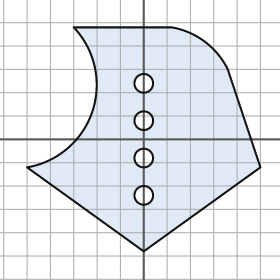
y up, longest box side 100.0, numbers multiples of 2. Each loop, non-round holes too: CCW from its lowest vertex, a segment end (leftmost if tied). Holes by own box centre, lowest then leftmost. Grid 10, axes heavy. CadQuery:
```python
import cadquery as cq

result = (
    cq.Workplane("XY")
    .moveTo(0.0, -48.0)
    .lineTo(50.0, -12.0)
    .lineTo(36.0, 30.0)
    .threePointArc((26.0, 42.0), (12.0, 48.0))
    .lineTo(-30.0, 48.0)
    .threePointArc((-22.0, 12.0), (-50.0, -12.0))
    .close()
    .moveTo(0.0, -24.0)
    .circle(4.0)
    .moveTo(0.0, -8.0)
    .circle(4.0)
    .moveTo(0.0, 8.0)
    .circle(4.0)
    .moveTo(0.0, 24.0)
    .circle(4.0)
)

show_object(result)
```